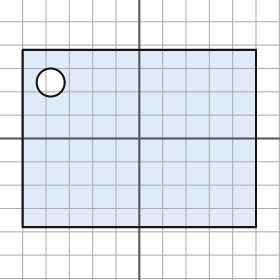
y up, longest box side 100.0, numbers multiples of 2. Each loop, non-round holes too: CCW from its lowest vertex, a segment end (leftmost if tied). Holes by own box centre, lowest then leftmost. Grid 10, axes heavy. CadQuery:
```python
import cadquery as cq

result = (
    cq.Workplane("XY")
    .moveTo(-50.0, -38.0)
    .lineTo(50.0, -38.0)
    .lineTo(50.0, 38.0)
    .lineTo(-50.0, 38.0)
    .close()
    .moveTo(-38.0, 24.0)
    .circle(6.0)
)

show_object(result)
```